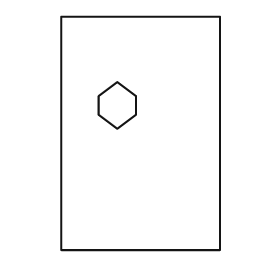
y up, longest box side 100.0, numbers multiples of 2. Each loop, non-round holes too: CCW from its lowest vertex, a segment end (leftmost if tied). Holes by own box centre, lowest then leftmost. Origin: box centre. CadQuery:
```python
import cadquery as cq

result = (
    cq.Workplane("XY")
    .moveTo(-34.0, -50.0)
    .lineTo(34.0, -50.0)
    .lineTo(34.0, 50.0)
    .lineTo(-34.0, 50.0)
    .close()
    .moveTo(-10.0, 2.0)
    .lineTo(-2.0, 8.0)
    .lineTo(-2.0, 16.0)
    .lineTo(-10.0, 22.0)
    .lineTo(-18.0, 16.0)
    .lineTo(-18.0, 8.0)
    .close()
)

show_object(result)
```